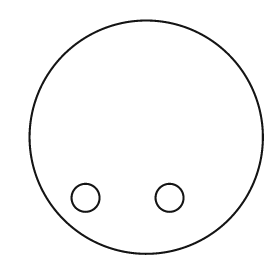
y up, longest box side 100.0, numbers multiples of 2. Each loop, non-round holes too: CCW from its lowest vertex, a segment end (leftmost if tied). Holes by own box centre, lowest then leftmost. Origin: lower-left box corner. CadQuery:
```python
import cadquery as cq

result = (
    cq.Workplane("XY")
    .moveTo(50.0, 50.0)
    .circle(50.0)
    .moveTo(24.0, 24.0)
    .circle(6.0)
    .moveTo(60.0, 24.0)
    .circle(6.0)
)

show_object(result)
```